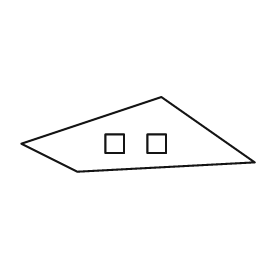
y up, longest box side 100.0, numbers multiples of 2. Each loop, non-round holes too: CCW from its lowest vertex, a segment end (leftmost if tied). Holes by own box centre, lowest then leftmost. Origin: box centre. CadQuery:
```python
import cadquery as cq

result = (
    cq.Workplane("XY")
    .moveTo(-26.0, -16.0)
    .lineTo(50.0, -12.0)
    .lineTo(10.0, 16.0)
    .lineTo(-50.0, -4.0)
    .close()
    .moveTo(-14.0, -8.0)
    .lineTo(-6.0, -8.0)
    .lineTo(-6.0, 0.0)
    .lineTo(-14.0, 0.0)
    .close()
    .moveTo(4.0, -8.0)
    .lineTo(12.0, -8.0)
    .lineTo(12.0, 0.0)
    .lineTo(4.0, 0.0)
    .close()
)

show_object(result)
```